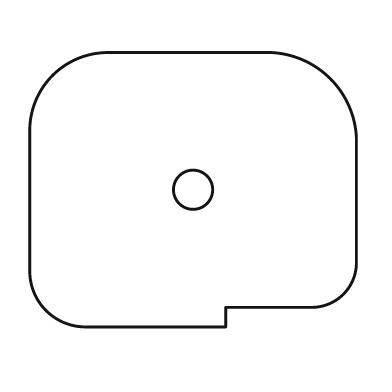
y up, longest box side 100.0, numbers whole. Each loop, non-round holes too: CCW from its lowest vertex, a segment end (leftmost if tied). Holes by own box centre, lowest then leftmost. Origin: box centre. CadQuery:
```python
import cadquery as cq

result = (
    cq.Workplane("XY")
    .moveTo(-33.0, -42.0)
    .lineTo(10.0, -42.0)
    .lineTo(10.0, -36.0)
    .lineTo(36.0, -36.0)
    .threePointArc((46.0, -32.0), (50.0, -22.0))
    .lineTo(50.0, 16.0)
    .threePointArc((42.0, 34.0), (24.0, 42.0))
    .lineTo(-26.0, 42.0)
    .threePointArc((-43.0, 35.0), (-50.0, 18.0))
    .lineTo(-50.0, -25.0)
    .threePointArc((-45.0, -37.0), (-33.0, -42.0))
    .close()
    .moveTo(0.0, 0.0)
    .circle(6.0)
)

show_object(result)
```